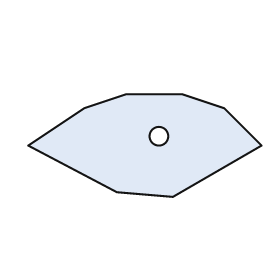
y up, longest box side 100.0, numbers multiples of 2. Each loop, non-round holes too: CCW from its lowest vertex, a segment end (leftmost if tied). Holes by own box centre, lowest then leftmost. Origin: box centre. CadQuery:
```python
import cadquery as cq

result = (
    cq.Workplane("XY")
    .moveTo(12.0, -22.0)
    .lineTo(50.0, 0.0)
    .lineTo(34.0, 16.0)
    .lineTo(16.0, 22.0)
    .lineTo(-8.0, 22.0)
    .lineTo(-26.0, 16.0)
    .lineTo(-50.0, 0.0)
    .lineTo(-12.0, -20.0)
    .close()
    .moveTo(6.0, 4.0)
    .circle(4.0)
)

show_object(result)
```